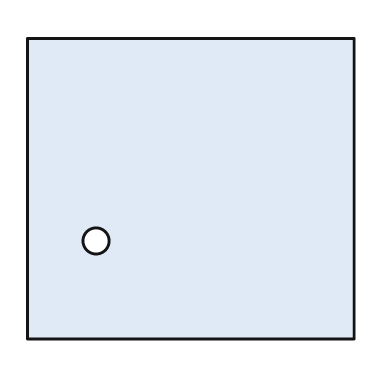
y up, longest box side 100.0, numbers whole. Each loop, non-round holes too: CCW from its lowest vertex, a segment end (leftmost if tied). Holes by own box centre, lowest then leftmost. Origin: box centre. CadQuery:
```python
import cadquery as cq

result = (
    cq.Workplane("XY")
    .moveTo(-50.0, -46.0)
    .lineTo(50.0, -46.0)
    .lineTo(50.0, 46.0)
    .lineTo(-50.0, 46.0)
    .close()
    .moveTo(-29.0, -16.0)
    .circle(4.0)
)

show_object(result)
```